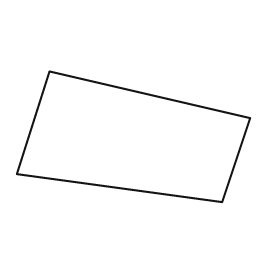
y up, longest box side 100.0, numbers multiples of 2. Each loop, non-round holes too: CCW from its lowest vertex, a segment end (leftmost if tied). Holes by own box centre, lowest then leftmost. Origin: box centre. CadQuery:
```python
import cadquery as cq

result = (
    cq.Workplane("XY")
    .moveTo(38.0, -28.0)
    .lineTo(50.0, 8.0)
    .lineTo(-36.0, 28.0)
    .lineTo(-50.0, -16.0)
    .close()
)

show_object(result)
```